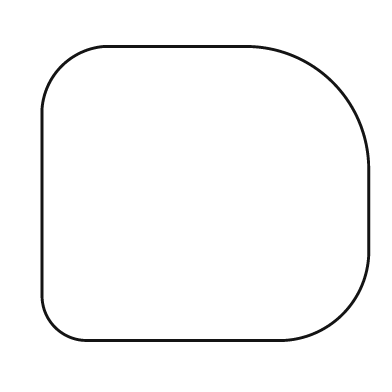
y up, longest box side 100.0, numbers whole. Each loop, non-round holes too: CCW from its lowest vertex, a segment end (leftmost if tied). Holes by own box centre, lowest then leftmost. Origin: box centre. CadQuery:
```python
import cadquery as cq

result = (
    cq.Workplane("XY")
    .moveTo(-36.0, -45.0)
    .lineTo(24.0, -45.0)
    .threePointArc((42.0, -37.0), (50.0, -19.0))
    .lineTo(50.0, 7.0)
    .threePointArc((39.0, 34.0), (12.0, 45.0))
    .lineTo(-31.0, 45.0)
    .threePointArc((-44.0, 39.0), (-50.0, 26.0))
    .lineTo(-50.0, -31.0)
    .threePointArc((-46.0, -41.0), (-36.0, -45.0))
    .close()
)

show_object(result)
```